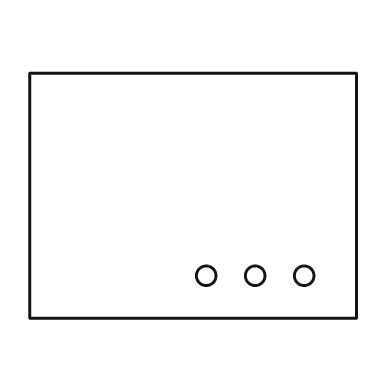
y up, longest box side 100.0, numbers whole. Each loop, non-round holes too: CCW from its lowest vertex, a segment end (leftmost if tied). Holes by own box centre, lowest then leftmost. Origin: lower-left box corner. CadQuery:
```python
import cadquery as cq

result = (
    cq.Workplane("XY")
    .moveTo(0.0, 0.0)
    .lineTo(100.0, 0.0)
    .lineTo(100.0, 75.0)
    .lineTo(0.0, 75.0)
    .close()
    .moveTo(54.0, 13.0)
    .circle(3.0)
    .moveTo(69.0, 13.0)
    .circle(3.0)
    .moveTo(84.0, 13.0)
    .circle(3.0)
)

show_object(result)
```